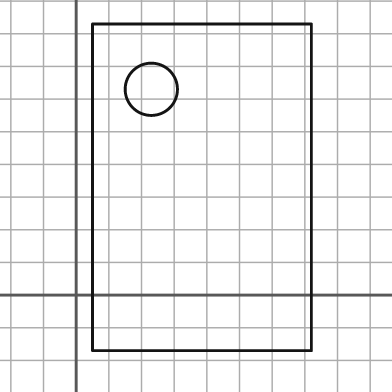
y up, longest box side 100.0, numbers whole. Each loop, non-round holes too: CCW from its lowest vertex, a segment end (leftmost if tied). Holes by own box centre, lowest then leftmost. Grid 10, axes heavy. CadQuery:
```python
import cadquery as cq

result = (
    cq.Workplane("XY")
    .moveTo(5.0, -17.0)
    .lineTo(72.0, -17.0)
    .lineTo(72.0, 83.0)
    .lineTo(5.0, 83.0)
    .close()
    .moveTo(23.0, 63.0)
    .circle(8.0)
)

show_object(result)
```